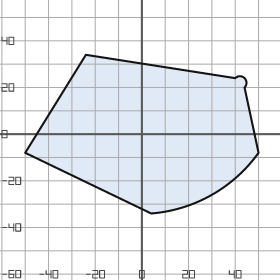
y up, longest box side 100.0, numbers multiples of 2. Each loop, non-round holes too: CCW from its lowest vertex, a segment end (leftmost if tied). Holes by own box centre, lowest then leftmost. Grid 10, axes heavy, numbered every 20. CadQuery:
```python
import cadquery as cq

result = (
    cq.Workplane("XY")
    .moveTo(4.0, -34.0)
    .threePointArc((30.0, -26.0), (50.0, -8.0))
    .lineTo(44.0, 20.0)
    .threePointArc((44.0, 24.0), (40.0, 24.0))
    .lineTo(-24.0, 34.0)
    .lineTo(-50.0, -8.0)
    .close()
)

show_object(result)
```